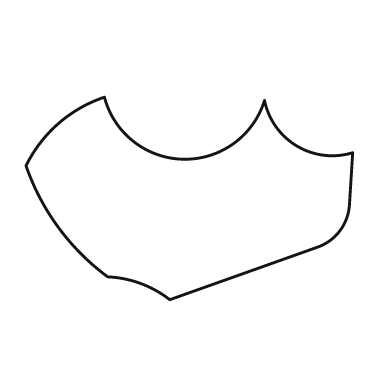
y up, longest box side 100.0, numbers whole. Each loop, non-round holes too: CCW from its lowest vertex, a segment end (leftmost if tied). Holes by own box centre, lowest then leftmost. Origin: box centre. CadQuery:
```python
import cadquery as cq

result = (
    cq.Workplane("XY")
    .moveTo(-6.0, -31.0)
    .lineTo(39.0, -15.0)
    .threePointArc((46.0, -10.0), (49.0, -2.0))
    .lineTo(50.0, 14.0)
    .threePointArc((33.0, 16.0), (23.0, 30.0))
    .threePointArc((-2.0, 12.0), (-26.0, 31.0))
    .threePointArc((-40.0, 23.0), (-50.0, 10.0))
    .threePointArc((-40.0, -9.0), (-25.0, -24.0))
    .threePointArc((-15.0, -26.0), (-6.0, -31.0))
    .close()
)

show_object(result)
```